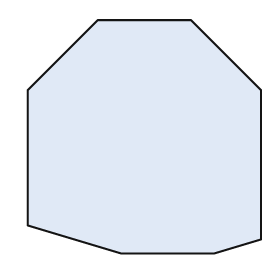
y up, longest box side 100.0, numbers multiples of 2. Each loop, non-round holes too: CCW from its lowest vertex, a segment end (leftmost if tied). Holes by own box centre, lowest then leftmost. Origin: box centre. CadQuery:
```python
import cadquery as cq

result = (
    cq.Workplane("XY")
    .moveTo(-10.0, -50.0)
    .lineTo(30.0, -50.0)
    .lineTo(50.0, -44.0)
    .lineTo(50.0, 20.0)
    .lineTo(20.0, 50.0)
    .lineTo(-20.0, 50.0)
    .lineTo(-50.0, 20.0)
    .lineTo(-50.0, -38.0)
    .close()
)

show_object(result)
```